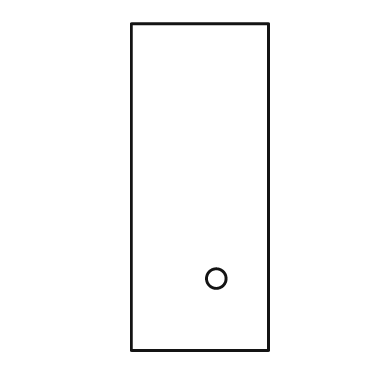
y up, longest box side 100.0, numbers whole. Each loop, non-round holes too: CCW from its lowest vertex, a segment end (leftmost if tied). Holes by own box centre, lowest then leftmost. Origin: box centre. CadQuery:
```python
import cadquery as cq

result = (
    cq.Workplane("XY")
    .moveTo(-21.0, -50.0)
    .lineTo(21.0, -50.0)
    .lineTo(21.0, 50.0)
    .lineTo(-21.0, 50.0)
    .close()
    .moveTo(5.0, -28.0)
    .circle(3.0)
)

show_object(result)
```